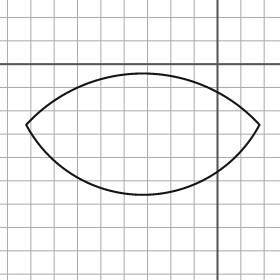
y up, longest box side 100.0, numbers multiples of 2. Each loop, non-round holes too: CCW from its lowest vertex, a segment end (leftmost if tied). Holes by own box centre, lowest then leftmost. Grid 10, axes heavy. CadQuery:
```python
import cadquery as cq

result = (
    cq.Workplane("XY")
    .moveTo(-82.0, -26.0)
    .threePointArc((-32.0, -56.0), (18.0, -26.0))
    .threePointArc((-32.0, -4.0), (-82.0, -26.0))
    .close()
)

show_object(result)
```